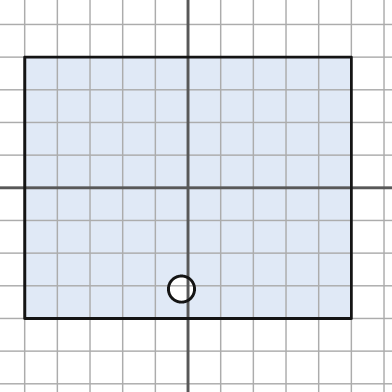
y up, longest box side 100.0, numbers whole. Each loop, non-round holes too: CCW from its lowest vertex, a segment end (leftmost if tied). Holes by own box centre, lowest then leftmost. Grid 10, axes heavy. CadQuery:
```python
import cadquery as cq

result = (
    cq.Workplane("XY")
    .moveTo(-50.0, -40.0)
    .lineTo(50.0, -40.0)
    .lineTo(50.0, 40.0)
    .lineTo(-50.0, 40.0)
    .close()
    .moveTo(-2.0, -31.0)
    .circle(4.0)
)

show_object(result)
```